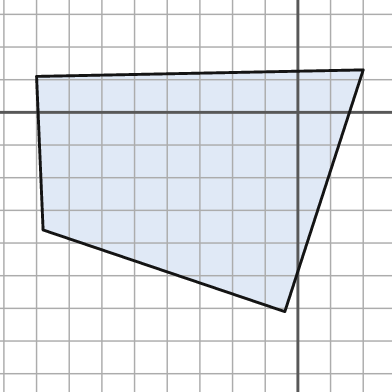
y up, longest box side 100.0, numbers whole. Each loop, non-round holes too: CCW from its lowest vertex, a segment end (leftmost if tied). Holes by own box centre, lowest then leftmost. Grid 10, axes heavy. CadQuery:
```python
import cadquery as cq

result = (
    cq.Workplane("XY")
    .moveTo(-4.0, -61.0)
    .lineTo(20.0, 13.0)
    .lineTo(-80.0, 11.0)
    .lineTo(-78.0, -36.0)
    .close()
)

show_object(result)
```